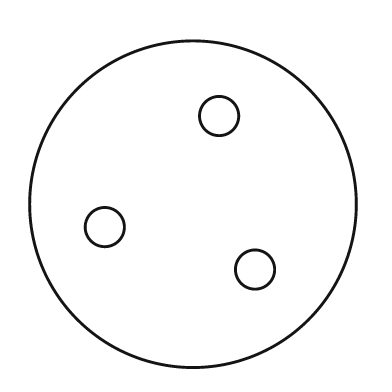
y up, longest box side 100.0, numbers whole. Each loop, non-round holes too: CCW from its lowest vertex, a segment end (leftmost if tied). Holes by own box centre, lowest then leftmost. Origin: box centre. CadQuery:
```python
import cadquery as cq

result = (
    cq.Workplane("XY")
    .moveTo(0.0, 0.0)
    .circle(50.0)
    .moveTo(19.0, -20.0)
    .circle(6.0)
    .moveTo(-27.0, -7.0)
    .circle(6.0)
    .moveTo(8.0, 27.0)
    .circle(6.0)
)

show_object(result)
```